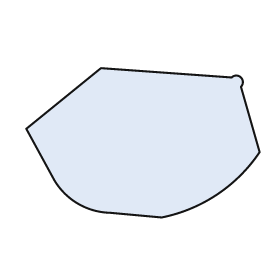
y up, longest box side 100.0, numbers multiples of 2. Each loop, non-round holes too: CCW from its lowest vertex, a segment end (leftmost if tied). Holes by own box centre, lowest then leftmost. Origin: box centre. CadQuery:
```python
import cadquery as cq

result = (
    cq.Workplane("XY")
    .moveTo(8.0, -32.0)
    .threePointArc((32.0, -22.0), (50.0, -4.0))
    .lineTo(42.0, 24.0)
    .threePointArc((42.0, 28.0), (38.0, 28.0))
    .lineTo(-18.0, 32.0)
    .lineTo(-50.0, 6.0)
    .lineTo(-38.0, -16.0)
    .threePointArc((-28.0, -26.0), (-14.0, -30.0))
    .close()
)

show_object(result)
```